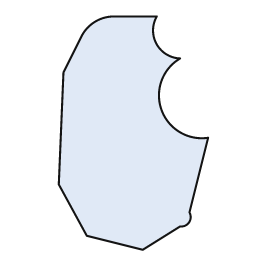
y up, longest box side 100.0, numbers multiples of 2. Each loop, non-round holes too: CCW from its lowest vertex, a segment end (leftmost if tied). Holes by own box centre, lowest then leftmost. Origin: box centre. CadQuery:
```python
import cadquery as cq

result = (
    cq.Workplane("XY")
    .moveTo(4.0, -50.0)
    .lineTo(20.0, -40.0)
    .threePointArc((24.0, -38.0), (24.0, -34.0))
    .lineTo(32.0, -2.0)
    .threePointArc((12.0, 10.0), (20.0, 32.0))
    .threePointArc((10.0, 38.0), (10.0, 50.0))
    .lineTo(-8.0, 50.0)
    .threePointArc((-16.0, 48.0), (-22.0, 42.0))
    .lineTo(-30.0, 26.0)
    .lineTo(-32.0, -22.0)
    .lineTo(-20.0, -44.0)
    .close()
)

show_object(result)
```